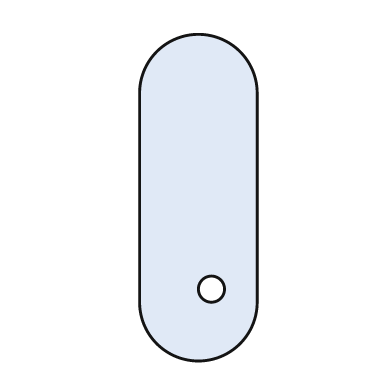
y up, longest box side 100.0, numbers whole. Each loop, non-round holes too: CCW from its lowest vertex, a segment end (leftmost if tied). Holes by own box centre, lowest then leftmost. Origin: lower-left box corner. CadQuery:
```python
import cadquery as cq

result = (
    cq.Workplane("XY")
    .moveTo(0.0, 18.0)
    .threePointArc((18.0, 0.0), (36.0, 18.0))
    .lineTo(36.0, 82.0)
    .threePointArc((18.0, 100.0), (0.0, 82.0))
    .close()
    .moveTo(22.0, 22.0)
    .circle(4.0)
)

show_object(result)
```